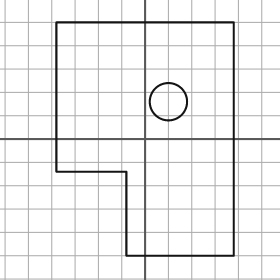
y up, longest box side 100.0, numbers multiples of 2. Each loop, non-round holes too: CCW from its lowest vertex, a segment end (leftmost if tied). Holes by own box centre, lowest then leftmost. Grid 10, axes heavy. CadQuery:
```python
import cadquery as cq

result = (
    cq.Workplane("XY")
    .moveTo(-8.0, -50.0)
    .lineTo(38.0, -50.0)
    .lineTo(38.0, 50.0)
    .lineTo(-38.0, 50.0)
    .lineTo(-38.0, -14.0)
    .lineTo(-8.0, -14.0)
    .close()
    .moveTo(10.0, 16.0)
    .circle(8.0)
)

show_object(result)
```